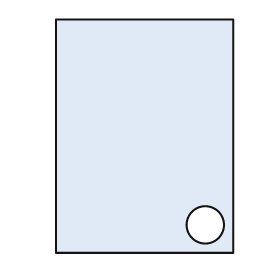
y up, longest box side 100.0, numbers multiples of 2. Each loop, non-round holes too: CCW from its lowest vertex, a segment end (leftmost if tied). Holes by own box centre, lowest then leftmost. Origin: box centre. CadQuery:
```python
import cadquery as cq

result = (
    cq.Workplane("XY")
    .moveTo(-38.0, -50.0)
    .lineTo(38.0, -50.0)
    .lineTo(38.0, 50.0)
    .lineTo(-38.0, 50.0)
    .close()
    .moveTo(26.0, -38.0)
    .circle(8.0)
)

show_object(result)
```